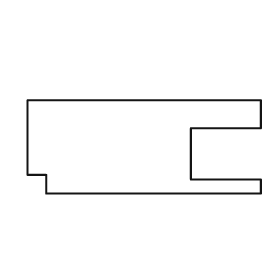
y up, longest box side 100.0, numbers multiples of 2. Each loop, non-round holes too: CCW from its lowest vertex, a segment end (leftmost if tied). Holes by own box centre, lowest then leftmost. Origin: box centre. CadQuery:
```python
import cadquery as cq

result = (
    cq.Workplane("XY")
    .moveTo(-42.0, -20.0)
    .lineTo(50.0, -20.0)
    .lineTo(50.0, -14.0)
    .lineTo(20.0, -14.0)
    .lineTo(20.0, 8.0)
    .lineTo(50.0, 8.0)
    .lineTo(50.0, 20.0)
    .lineTo(-50.0, 20.0)
    .lineTo(-50.0, -12.0)
    .lineTo(-42.0, -12.0)
    .close()
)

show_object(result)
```